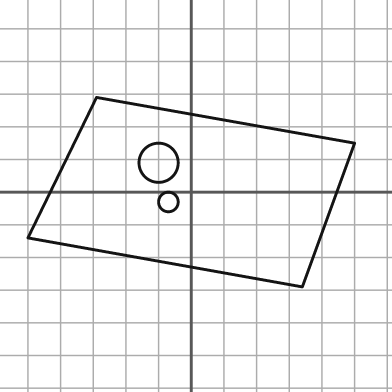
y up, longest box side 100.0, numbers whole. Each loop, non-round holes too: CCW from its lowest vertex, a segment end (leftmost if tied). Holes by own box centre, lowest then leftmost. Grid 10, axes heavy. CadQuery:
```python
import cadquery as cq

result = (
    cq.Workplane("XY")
    .moveTo(34.0, -29.0)
    .lineTo(50.0, 15.0)
    .lineTo(-29.0, 29.0)
    .lineTo(-50.0, -14.0)
    .close()
    .moveTo(-7.0, -3.0)
    .circle(3.0)
    .moveTo(-10.0, 9.0)
    .circle(6.0)
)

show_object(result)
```